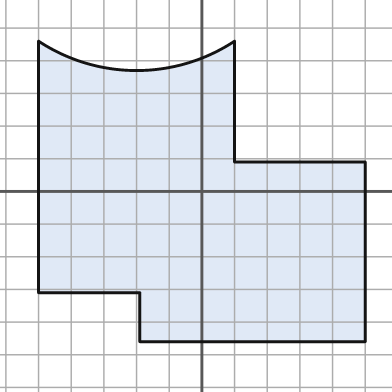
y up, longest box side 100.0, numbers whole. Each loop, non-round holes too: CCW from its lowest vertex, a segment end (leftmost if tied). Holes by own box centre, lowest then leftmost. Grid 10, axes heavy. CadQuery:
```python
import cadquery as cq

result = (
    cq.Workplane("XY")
    .moveTo(-19.0, -46.0)
    .lineTo(50.0, -46.0)
    .lineTo(50.0, 9.0)
    .lineTo(10.0, 9.0)
    .lineTo(10.0, 46.0)
    .threePointArc((-20.0, 37.0), (-50.0, 46.0))
    .lineTo(-50.0, -31.0)
    .lineTo(-19.0, -31.0)
    .close()
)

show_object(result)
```